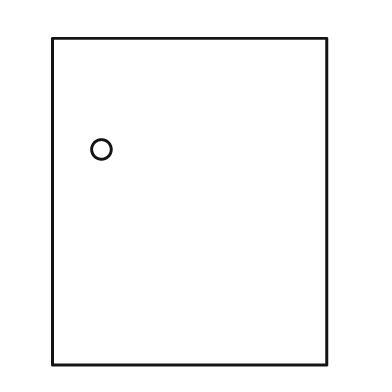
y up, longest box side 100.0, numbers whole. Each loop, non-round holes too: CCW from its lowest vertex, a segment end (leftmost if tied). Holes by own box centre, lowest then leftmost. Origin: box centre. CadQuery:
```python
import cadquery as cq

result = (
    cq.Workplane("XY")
    .moveTo(-42.0, -50.0)
    .lineTo(42.0, -50.0)
    .lineTo(42.0, 50.0)
    .lineTo(-42.0, 50.0)
    .close()
    .moveTo(-27.0, 16.0)
    .circle(3.0)
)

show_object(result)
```